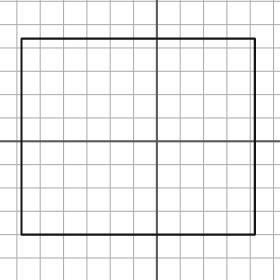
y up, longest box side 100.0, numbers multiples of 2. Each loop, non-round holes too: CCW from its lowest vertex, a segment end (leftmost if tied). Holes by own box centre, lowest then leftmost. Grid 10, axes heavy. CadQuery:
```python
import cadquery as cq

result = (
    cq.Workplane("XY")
    .moveTo(-58.0, -40.0)
    .lineTo(42.0, -40.0)
    .lineTo(42.0, 44.0)
    .lineTo(-58.0, 44.0)
    .close()
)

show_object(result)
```